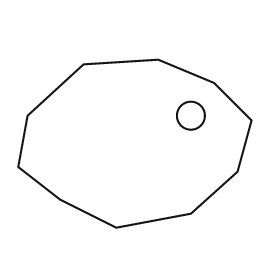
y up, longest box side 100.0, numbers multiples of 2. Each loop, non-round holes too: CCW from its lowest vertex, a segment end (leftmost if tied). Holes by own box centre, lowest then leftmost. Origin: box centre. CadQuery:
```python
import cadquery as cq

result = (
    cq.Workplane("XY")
    .moveTo(-8.0, -36.0)
    .lineTo(24.0, -30.0)
    .lineTo(44.0, -12.0)
    .lineTo(50.0, 10.0)
    .lineTo(34.0, 26.0)
    .lineTo(10.0, 36.0)
    .lineTo(-22.0, 34.0)
    .lineTo(-46.0, 12.0)
    .lineTo(-50.0, -10.0)
    .lineTo(-32.0, -24.0)
    .close()
    .moveTo(24.0, 12.0)
    .circle(6.0)
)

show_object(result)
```